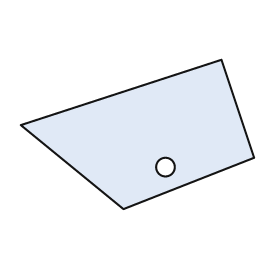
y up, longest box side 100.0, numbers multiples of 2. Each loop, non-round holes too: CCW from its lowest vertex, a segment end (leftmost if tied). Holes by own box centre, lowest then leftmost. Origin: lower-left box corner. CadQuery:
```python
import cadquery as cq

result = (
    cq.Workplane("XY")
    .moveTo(44.0, 0.0)
    .lineTo(100.0, 22.0)
    .lineTo(86.0, 64.0)
    .lineTo(0.0, 36.0)
    .close()
    .moveTo(62.0, 18.0)
    .circle(4.0)
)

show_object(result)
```